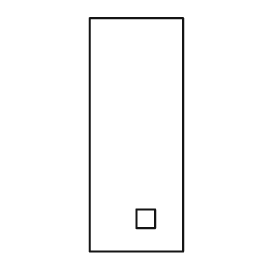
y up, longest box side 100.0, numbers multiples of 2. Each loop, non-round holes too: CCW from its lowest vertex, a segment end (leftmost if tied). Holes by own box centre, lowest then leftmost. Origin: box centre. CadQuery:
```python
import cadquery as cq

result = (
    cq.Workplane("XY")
    .moveTo(-20.0, -50.0)
    .lineTo(20.0, -50.0)
    .lineTo(20.0, 50.0)
    .lineTo(-20.0, 50.0)
    .close()
    .moveTo(0.0, -40.0)
    .lineTo(8.0, -40.0)
    .lineTo(8.0, -32.0)
    .lineTo(0.0, -32.0)
    .close()
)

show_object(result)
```